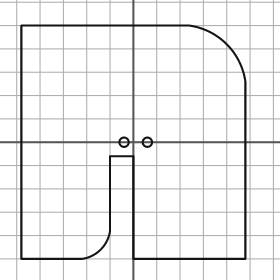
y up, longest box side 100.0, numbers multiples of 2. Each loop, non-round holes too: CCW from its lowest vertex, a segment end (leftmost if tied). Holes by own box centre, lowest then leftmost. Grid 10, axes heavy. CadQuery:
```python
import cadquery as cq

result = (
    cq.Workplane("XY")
    .moveTo(-48.0, -50.0)
    .lineTo(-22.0, -50.0)
    .threePointArc((-14.0, -46.0), (-10.0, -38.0))
    .lineTo(-10.0, -6.0)
    .lineTo(0.0, -6.0)
    .lineTo(0.0, -50.0)
    .lineTo(48.0, -50.0)
    .lineTo(48.0, 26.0)
    .threePointArc((40.0, 42.0), (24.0, 50.0))
    .lineTo(-48.0, 50.0)
    .close()
    .moveTo(-4.0, 0.0)
    .circle(2.0)
    .moveTo(6.0, 0.0)
    .circle(2.0)
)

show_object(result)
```